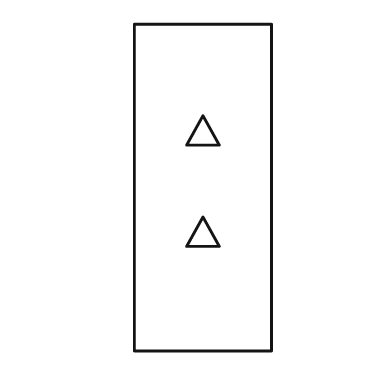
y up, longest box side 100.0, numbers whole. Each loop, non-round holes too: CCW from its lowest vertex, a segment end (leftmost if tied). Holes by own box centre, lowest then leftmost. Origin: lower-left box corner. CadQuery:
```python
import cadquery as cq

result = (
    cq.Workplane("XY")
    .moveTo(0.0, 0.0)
    .lineTo(42.0, 0.0)
    .lineTo(42.0, 100.0)
    .lineTo(0.0, 100.0)
    .close()
    .moveTo(16.0, 32.0)
    .lineTo(26.0, 32.0)
    .lineTo(21.0, 41.0)
    .close()
    .moveTo(16.0, 63.0)
    .lineTo(26.0, 63.0)
    .lineTo(21.0, 72.0)
    .close()
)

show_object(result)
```